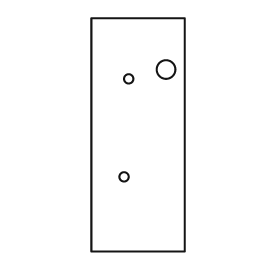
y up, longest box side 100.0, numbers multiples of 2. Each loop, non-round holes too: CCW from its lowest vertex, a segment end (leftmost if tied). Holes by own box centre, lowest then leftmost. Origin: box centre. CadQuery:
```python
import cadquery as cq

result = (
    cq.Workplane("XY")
    .moveTo(-20.0, -50.0)
    .lineTo(20.0, -50.0)
    .lineTo(20.0, 50.0)
    .lineTo(-20.0, 50.0)
    .close()
    .moveTo(-6.0, -18.0)
    .circle(2.0)
    .moveTo(-4.0, 24.0)
    .circle(2.0)
    .moveTo(12.0, 28.0)
    .circle(4.0)
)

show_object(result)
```